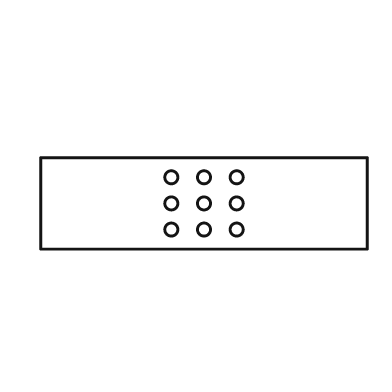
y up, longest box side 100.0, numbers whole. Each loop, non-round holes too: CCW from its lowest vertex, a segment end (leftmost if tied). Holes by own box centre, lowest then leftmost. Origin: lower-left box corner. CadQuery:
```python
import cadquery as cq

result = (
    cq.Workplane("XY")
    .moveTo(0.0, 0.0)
    .lineTo(100.0, 0.0)
    .lineTo(100.0, 28.0)
    .lineTo(0.0, 28.0)
    .close()
    .moveTo(40.0, 6.0)
    .circle(2.0)
    .moveTo(50.0, 6.0)
    .circle(2.0)
    .moveTo(60.0, 6.0)
    .circle(2.0)
    .moveTo(40.0, 14.0)
    .circle(2.0)
    .moveTo(50.0, 14.0)
    .circle(2.0)
    .moveTo(60.0, 14.0)
    .circle(2.0)
    .moveTo(40.0, 22.0)
    .circle(2.0)
    .moveTo(50.0, 22.0)
    .circle(2.0)
    .moveTo(60.0, 22.0)
    .circle(2.0)
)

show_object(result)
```